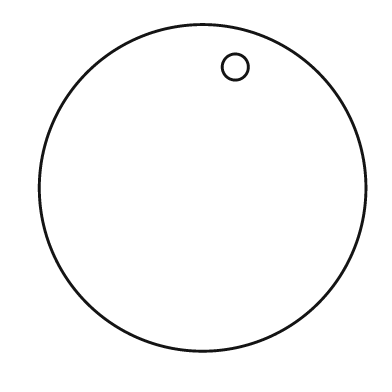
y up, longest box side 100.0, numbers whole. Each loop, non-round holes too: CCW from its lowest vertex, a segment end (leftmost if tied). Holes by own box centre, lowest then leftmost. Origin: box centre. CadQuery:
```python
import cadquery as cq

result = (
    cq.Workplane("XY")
    .moveTo(0.0, 0.0)
    .circle(50.0)
    .moveTo(10.0, 37.0)
    .circle(4.0)
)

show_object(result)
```